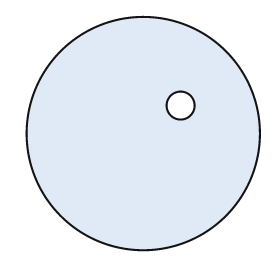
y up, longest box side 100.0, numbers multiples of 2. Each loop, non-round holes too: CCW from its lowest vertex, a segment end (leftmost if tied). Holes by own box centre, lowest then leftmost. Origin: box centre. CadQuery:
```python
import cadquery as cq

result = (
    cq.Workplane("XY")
    .moveTo(0.0, 0.0)
    .circle(50.0)
    .moveTo(16.0, 12.0)
    .circle(6.0)
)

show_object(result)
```